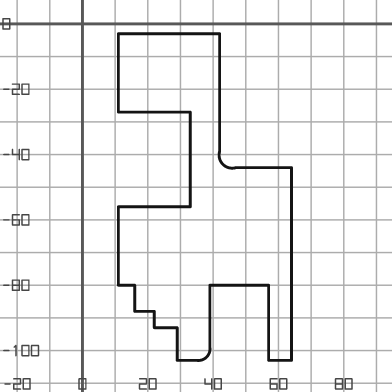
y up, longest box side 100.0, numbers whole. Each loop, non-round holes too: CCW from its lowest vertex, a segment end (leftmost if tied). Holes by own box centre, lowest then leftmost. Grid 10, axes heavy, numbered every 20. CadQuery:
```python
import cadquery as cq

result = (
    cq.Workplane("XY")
    .moveTo(29.0, -103.0)
    .lineTo(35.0, -103.0)
    .threePointArc((38.0, -102.0), (39.0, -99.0))
    .lineTo(39.0, -80.0)
    .lineTo(57.0, -80.0)
    .lineTo(57.0, -103.0)
    .lineTo(64.0, -103.0)
    .lineTo(64.0, -44.0)
    .lineTo(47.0, -44.0)
    .threePointArc((43.0, -43.0), (42.0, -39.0))
    .lineTo(42.0, -3.0)
    .lineTo(11.0, -3.0)
    .lineTo(11.0, -27.0)
    .lineTo(33.0, -27.0)
    .lineTo(33.0, -56.0)
    .lineTo(11.0, -56.0)
    .lineTo(11.0, -80.0)
    .lineTo(16.0, -80.0)
    .lineTo(16.0, -88.0)
    .lineTo(22.0, -88.0)
    .lineTo(22.0, -93.0)
    .lineTo(29.0, -93.0)
    .close()
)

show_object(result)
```